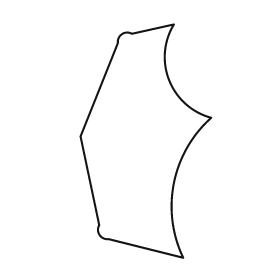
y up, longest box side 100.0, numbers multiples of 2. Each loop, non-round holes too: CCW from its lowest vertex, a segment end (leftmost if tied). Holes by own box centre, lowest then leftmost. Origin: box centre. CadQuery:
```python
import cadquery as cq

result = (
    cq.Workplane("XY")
    .moveTo(16.0, -50.0)
    .threePointArc((12.0, -18.0), (28.0, 10.0))
    .threePointArc((10.0, 26.0), (12.0, 50.0))
    .lineTo(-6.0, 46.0)
    .threePointArc((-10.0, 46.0), (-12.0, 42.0))
    .lineTo(-28.0, 2.0)
    .lineTo(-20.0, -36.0)
    .threePointArc((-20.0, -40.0), (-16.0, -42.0))
    .close()
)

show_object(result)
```